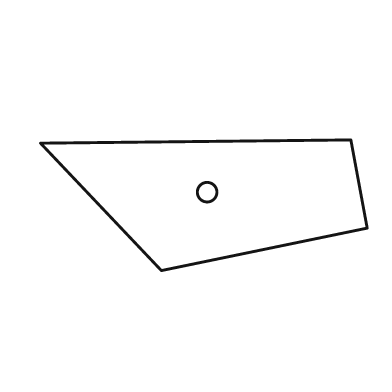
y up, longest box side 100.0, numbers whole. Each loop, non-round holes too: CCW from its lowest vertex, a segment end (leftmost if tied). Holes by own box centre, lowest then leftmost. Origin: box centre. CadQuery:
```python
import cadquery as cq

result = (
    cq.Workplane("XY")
    .moveTo(-13.0, -20.0)
    .lineTo(50.0, -7.0)
    .lineTo(45.0, 20.0)
    .lineTo(-50.0, 19.0)
    .close()
    .moveTo(1.0, 4.0)
    .circle(3.0)
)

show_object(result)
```